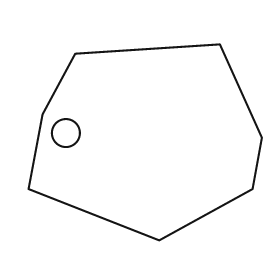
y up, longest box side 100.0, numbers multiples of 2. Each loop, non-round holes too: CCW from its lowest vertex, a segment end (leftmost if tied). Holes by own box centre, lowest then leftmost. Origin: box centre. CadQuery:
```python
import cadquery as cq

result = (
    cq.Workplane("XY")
    .moveTo(6.0, -42.0)
    .lineTo(46.0, -20.0)
    .lineTo(50.0, 2.0)
    .lineTo(32.0, 42.0)
    .lineTo(-30.0, 38.0)
    .lineTo(-44.0, 12.0)
    .lineTo(-50.0, -20.0)
    .close()
    .moveTo(-34.0, 4.0)
    .circle(6.0)
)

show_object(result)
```